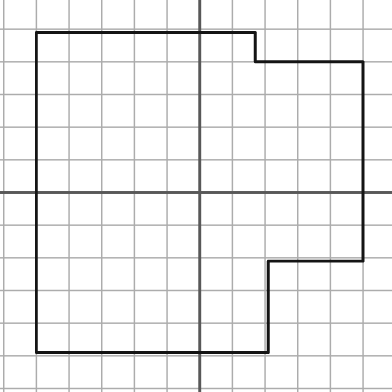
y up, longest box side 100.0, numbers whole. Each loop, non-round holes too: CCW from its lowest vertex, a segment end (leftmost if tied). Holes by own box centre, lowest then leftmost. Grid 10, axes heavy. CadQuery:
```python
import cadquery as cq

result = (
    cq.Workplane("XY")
    .moveTo(-50.0, -49.0)
    .lineTo(21.0, -49.0)
    .lineTo(21.0, -21.0)
    .lineTo(50.0, -21.0)
    .lineTo(50.0, 40.0)
    .lineTo(17.0, 40.0)
    .lineTo(17.0, 49.0)
    .lineTo(-50.0, 49.0)
    .close()
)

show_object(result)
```